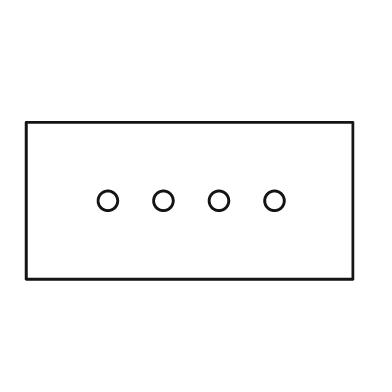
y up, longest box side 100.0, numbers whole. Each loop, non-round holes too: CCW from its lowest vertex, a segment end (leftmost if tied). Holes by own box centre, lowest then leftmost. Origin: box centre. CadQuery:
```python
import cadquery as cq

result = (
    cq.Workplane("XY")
    .moveTo(-50.0, -24.0)
    .lineTo(50.0, -24.0)
    .lineTo(50.0, 24.0)
    .lineTo(-50.0, 24.0)
    .close()
    .moveTo(-25.0, 0.0)
    .circle(3.0)
    .moveTo(-8.0, 0.0)
    .circle(3.0)
    .moveTo(9.0, 0.0)
    .circle(3.0)
    .moveTo(26.0, 0.0)
    .circle(3.0)
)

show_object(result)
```